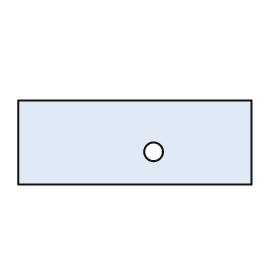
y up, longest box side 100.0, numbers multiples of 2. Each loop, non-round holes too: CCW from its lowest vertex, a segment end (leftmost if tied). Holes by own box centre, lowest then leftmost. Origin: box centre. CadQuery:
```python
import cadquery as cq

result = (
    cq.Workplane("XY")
    .moveTo(-50.0, -18.0)
    .lineTo(50.0, -18.0)
    .lineTo(50.0, 18.0)
    .lineTo(-50.0, 18.0)
    .close()
    .moveTo(8.0, -4.0)
    .circle(4.0)
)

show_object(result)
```